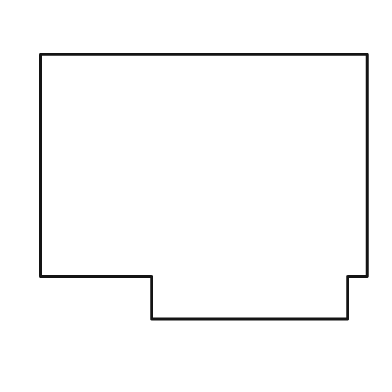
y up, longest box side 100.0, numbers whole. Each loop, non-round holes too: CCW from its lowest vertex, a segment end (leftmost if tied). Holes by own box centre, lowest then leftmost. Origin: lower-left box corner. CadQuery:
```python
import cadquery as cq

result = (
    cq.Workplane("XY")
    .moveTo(34.0, 0.0)
    .lineTo(94.0, 0.0)
    .lineTo(94.0, 13.0)
    .lineTo(100.0, 13.0)
    .lineTo(100.0, 81.0)
    .lineTo(0.0, 81.0)
    .lineTo(0.0, 13.0)
    .lineTo(34.0, 13.0)
    .close()
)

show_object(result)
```